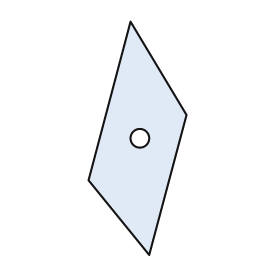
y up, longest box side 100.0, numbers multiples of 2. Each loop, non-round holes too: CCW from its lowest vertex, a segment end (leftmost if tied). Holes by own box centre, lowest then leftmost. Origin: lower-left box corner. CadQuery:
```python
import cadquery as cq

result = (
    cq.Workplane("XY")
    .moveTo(26.0, 0.0)
    .lineTo(42.0, 60.0)
    .lineTo(18.0, 100.0)
    .lineTo(0.0, 32.0)
    .close()
    .moveTo(22.0, 50.0)
    .circle(4.0)
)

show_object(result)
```